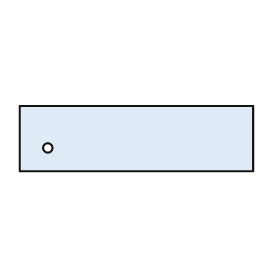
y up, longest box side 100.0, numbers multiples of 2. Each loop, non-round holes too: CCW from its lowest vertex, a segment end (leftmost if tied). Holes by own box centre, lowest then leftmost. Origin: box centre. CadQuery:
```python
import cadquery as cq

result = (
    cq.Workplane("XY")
    .moveTo(-50.0, -14.0)
    .lineTo(50.0, -14.0)
    .lineTo(50.0, 14.0)
    .lineTo(-50.0, 14.0)
    .close()
    .moveTo(-38.0, -4.0)
    .circle(2.0)
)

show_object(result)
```